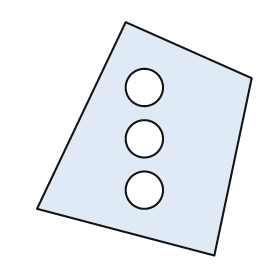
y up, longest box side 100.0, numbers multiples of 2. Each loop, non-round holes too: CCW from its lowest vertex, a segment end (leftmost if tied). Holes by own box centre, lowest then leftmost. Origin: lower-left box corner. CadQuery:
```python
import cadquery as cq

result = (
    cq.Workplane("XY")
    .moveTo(76.0, 0.0)
    .lineTo(92.0, 76.0)
    .lineTo(38.0, 100.0)
    .lineTo(0.0, 20.0)
    .close()
    .moveTo(46.0, 28.0)
    .circle(8.0)
    .moveTo(46.0, 50.0)
    .circle(8.0)
    .moveTo(46.0, 72.0)
    .circle(8.0)
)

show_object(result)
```